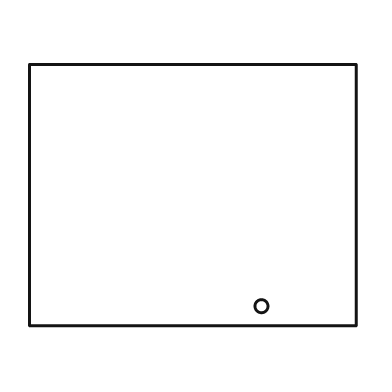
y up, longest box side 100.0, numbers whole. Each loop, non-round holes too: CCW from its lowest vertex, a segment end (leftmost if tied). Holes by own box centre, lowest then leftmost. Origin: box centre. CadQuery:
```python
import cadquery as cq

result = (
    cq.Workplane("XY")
    .moveTo(-50.0, -40.0)
    .lineTo(50.0, -40.0)
    .lineTo(50.0, 40.0)
    .lineTo(-50.0, 40.0)
    .close()
    .moveTo(21.0, -34.0)
    .circle(2.0)
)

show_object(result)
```